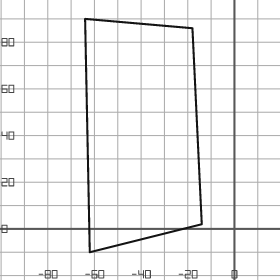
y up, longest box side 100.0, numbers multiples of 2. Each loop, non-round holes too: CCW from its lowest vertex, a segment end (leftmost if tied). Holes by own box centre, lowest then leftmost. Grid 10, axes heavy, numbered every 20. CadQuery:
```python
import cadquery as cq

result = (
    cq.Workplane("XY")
    .moveTo(-62.0, -10.0)
    .lineTo(-14.0, 2.0)
    .lineTo(-18.0, 86.0)
    .lineTo(-64.0, 90.0)
    .close()
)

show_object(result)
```